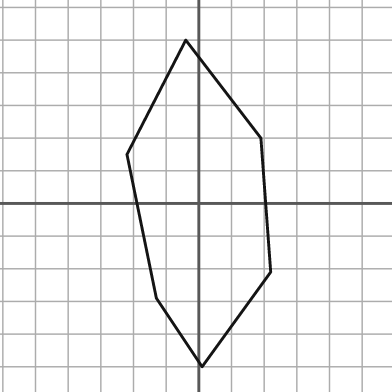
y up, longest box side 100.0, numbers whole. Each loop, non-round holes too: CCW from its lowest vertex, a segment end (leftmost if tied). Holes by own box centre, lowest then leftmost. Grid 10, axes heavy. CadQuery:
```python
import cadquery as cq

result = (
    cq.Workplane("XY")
    .moveTo(1.0, -50.0)
    .lineTo(22.0, -21.0)
    .lineTo(19.0, 20.0)
    .lineTo(-4.0, 50.0)
    .lineTo(-22.0, 15.0)
    .lineTo(-13.0, -29.0)
    .close()
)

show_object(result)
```